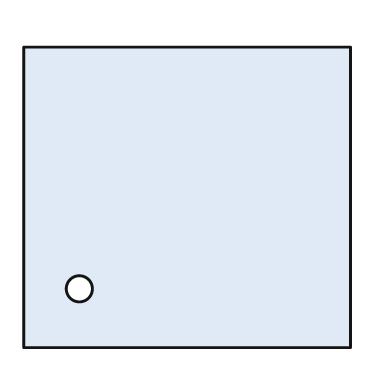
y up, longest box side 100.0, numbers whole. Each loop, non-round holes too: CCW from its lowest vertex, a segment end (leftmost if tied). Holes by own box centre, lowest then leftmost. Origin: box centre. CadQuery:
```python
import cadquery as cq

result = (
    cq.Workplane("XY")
    .moveTo(-50.0, -46.0)
    .lineTo(50.0, -46.0)
    .lineTo(50.0, 46.0)
    .lineTo(-50.0, 46.0)
    .close()
    .moveTo(-33.0, -28.0)
    .circle(4.0)
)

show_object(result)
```